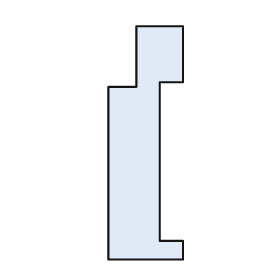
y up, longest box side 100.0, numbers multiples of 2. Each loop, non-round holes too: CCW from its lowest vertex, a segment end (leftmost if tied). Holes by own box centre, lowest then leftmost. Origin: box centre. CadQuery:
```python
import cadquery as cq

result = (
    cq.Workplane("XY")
    .moveTo(-16.0, -50.0)
    .lineTo(16.0, -50.0)
    .lineTo(16.0, -42.0)
    .lineTo(6.0, -42.0)
    .lineTo(6.0, 26.0)
    .lineTo(16.0, 26.0)
    .lineTo(16.0, 50.0)
    .lineTo(-4.0, 50.0)
    .lineTo(-4.0, 24.0)
    .lineTo(-16.0, 24.0)
    .close()
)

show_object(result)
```